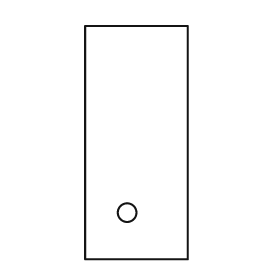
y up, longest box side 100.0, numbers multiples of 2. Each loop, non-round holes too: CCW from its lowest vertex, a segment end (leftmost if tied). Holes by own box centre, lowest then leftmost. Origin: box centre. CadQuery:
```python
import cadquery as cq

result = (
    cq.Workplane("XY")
    .moveTo(-22.0, -50.0)
    .lineTo(22.0, -50.0)
    .lineTo(22.0, 50.0)
    .lineTo(-22.0, 50.0)
    .close()
    .moveTo(-4.0, -30.0)
    .circle(4.0)
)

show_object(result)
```